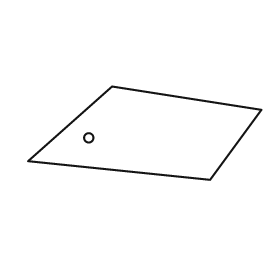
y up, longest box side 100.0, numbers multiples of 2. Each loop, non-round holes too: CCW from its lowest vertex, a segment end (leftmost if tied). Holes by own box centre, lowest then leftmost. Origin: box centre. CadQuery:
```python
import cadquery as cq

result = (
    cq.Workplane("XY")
    .moveTo(28.0, -20.0)
    .lineTo(50.0, 10.0)
    .lineTo(-14.0, 20.0)
    .lineTo(-50.0, -12.0)
    .close()
    .moveTo(-24.0, -2.0)
    .circle(2.0)
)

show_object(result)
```